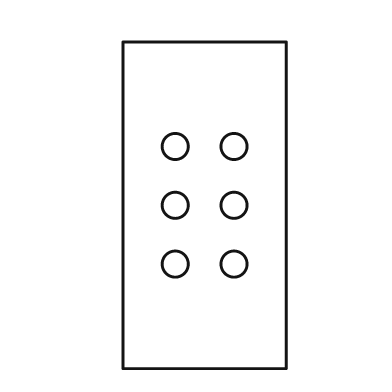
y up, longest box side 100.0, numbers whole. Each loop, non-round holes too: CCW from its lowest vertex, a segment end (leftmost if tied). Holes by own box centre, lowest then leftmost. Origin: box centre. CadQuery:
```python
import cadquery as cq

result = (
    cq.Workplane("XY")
    .moveTo(-25.0, -50.0)
    .lineTo(25.0, -50.0)
    .lineTo(25.0, 50.0)
    .lineTo(-25.0, 50.0)
    .close()
    .moveTo(-9.0, -18.0)
    .circle(4.0)
    .moveTo(9.0, -18.0)
    .circle(4.0)
    .moveTo(-9.0, 0.0)
    .circle(4.0)
    .moveTo(9.0, 0.0)
    .circle(4.0)
    .moveTo(-9.0, 18.0)
    .circle(4.0)
    .moveTo(9.0, 18.0)
    .circle(4.0)
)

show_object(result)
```